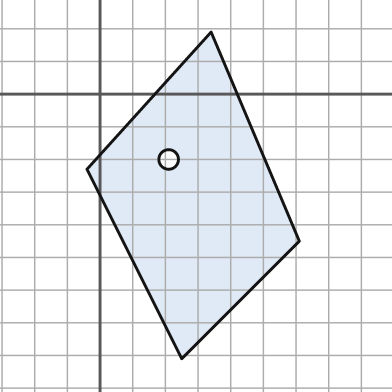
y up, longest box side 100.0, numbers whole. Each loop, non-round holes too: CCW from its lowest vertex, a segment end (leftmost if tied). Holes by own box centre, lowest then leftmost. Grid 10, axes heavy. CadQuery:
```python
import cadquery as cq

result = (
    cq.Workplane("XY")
    .moveTo(25.0, -81.0)
    .lineTo(61.0, -45.0)
    .lineTo(34.0, 19.0)
    .lineTo(-4.0, -23.0)
    .close()
    .moveTo(21.0, -20.0)
    .circle(3.0)
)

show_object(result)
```